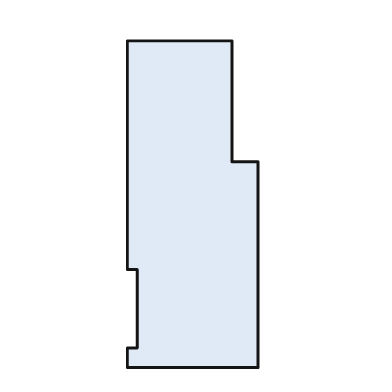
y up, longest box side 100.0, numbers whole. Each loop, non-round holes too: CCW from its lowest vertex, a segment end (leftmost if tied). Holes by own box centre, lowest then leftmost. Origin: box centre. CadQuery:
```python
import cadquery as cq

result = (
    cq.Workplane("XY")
    .moveTo(-20.0, -50.0)
    .lineTo(20.0, -50.0)
    .lineTo(20.0, 13.0)
    .lineTo(12.0, 13.0)
    .lineTo(12.0, 50.0)
    .lineTo(-20.0, 50.0)
    .lineTo(-20.0, -20.0)
    .lineTo(-17.0, -20.0)
    .lineTo(-17.0, -44.0)
    .lineTo(-20.0, -44.0)
    .close()
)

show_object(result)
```